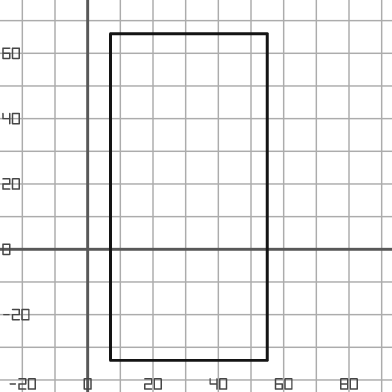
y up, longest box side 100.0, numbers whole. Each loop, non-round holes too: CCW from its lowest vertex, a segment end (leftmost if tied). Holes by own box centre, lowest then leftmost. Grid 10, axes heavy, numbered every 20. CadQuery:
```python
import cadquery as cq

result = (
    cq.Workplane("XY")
    .moveTo(7.0, -34.0)
    .lineTo(55.0, -34.0)
    .lineTo(55.0, 66.0)
    .lineTo(7.0, 66.0)
    .close()
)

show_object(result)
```